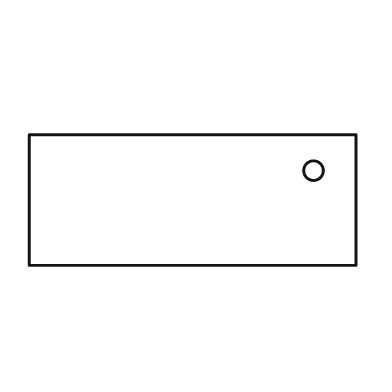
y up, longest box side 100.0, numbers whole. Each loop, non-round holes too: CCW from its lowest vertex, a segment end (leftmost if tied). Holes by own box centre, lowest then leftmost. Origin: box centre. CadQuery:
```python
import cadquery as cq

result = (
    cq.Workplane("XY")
    .moveTo(-50.0, -20.0)
    .lineTo(50.0, -20.0)
    .lineTo(50.0, 20.0)
    .lineTo(-50.0, 20.0)
    .close()
    .moveTo(37.0, 9.0)
    .circle(3.0)
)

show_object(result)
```